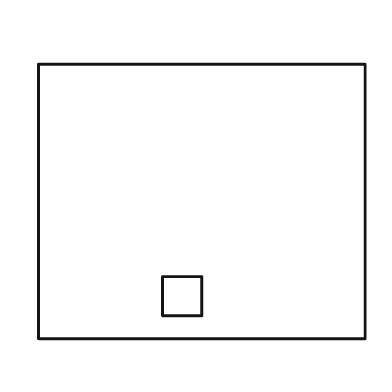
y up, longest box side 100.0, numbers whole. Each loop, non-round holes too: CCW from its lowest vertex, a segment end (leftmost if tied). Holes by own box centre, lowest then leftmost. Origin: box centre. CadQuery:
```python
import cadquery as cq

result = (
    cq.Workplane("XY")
    .moveTo(-50.0, -42.0)
    .lineTo(50.0, -42.0)
    .lineTo(50.0, 42.0)
    .lineTo(-50.0, 42.0)
    .close()
    .moveTo(-12.0, -35.0)
    .lineTo(0.0, -35.0)
    .lineTo(0.0, -23.0)
    .lineTo(-12.0, -23.0)
    .close()
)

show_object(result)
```